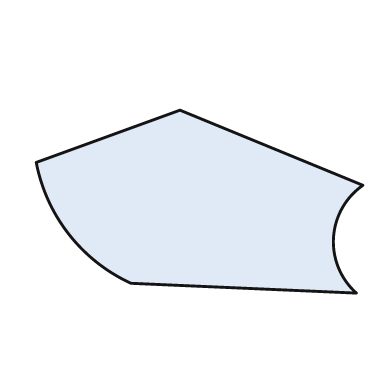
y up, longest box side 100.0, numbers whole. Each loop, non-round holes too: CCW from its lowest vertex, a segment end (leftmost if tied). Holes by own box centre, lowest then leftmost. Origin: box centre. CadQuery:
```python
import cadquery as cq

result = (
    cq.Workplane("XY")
    .moveTo(48.0, -28.0)
    .threePointArc((41.0, -11.0), (50.0, 5.0))
    .lineTo(-6.0, 28.0)
    .lineTo(-50.0, 12.0)
    .threePointArc((-40.0, -10.0), (-21.0, -25.0))
    .close()
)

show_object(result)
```